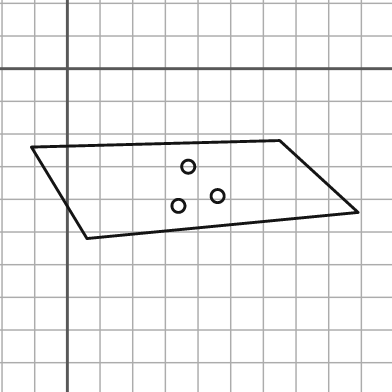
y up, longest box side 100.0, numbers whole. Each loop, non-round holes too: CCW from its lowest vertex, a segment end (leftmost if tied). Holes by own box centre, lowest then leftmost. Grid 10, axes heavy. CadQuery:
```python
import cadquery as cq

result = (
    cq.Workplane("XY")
    .moveTo(6.0, -52.0)
    .lineTo(89.0, -44.0)
    .lineTo(65.0, -22.0)
    .lineTo(-11.0, -24.0)
    .close()
    .moveTo(34.0, -42.0)
    .circle(2.0)
    .moveTo(46.0, -39.0)
    .circle(2.0)
    .moveTo(37.0, -30.0)
    .circle(2.0)
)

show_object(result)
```